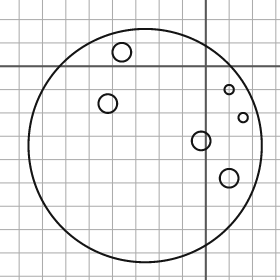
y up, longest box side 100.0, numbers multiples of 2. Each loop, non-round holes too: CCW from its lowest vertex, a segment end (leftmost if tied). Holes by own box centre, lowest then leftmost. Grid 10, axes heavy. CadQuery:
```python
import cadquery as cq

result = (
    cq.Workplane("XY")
    .moveTo(-26.0, -34.0)
    .circle(50.0)
    .moveTo(10.0, -48.0)
    .circle(4.0)
    .moveTo(-2.0, -32.0)
    .circle(4.0)
    .moveTo(16.0, -22.0)
    .circle(2.0)
    .moveTo(-42.0, -16.0)
    .circle(4.0)
    .moveTo(10.0, -10.0)
    .circle(2.0)
    .moveTo(-36.0, 6.0)
    .circle(4.0)
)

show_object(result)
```